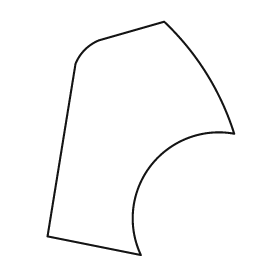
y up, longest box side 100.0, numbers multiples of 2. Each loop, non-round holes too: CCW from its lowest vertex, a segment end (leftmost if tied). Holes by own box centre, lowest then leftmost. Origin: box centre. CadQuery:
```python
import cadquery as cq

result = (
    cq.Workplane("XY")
    .moveTo(0.0, -50.0)
    .threePointArc((4.0, -12.0), (40.0, 2.0))
    .threePointArc((28.0, 28.0), (10.0, 50.0))
    .lineTo(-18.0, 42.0)
    .threePointArc((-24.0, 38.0), (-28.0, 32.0))
    .lineTo(-40.0, -42.0)
    .close()
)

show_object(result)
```